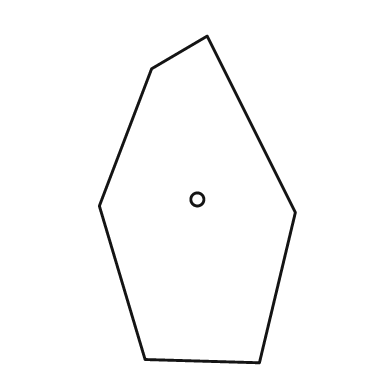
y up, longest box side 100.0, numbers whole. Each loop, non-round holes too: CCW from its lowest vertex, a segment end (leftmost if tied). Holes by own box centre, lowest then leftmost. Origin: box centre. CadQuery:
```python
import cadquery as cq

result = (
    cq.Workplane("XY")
    .moveTo(19.0, -50.0)
    .lineTo(30.0, -4.0)
    .lineTo(3.0, 50.0)
    .lineTo(-14.0, 40.0)
    .lineTo(-30.0, -2.0)
    .lineTo(-16.0, -49.0)
    .close()
    .moveTo(0.0, 0.0)
    .circle(2.0)
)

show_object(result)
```